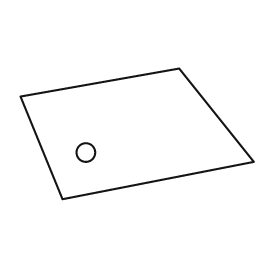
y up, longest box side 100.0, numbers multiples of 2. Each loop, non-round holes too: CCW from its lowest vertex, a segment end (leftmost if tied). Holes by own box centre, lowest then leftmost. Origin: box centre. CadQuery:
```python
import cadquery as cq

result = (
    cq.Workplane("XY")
    .moveTo(-32.0, -28.0)
    .lineTo(50.0, -12.0)
    .lineTo(18.0, 28.0)
    .lineTo(-50.0, 16.0)
    .close()
    .moveTo(-22.0, -8.0)
    .circle(4.0)
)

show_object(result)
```